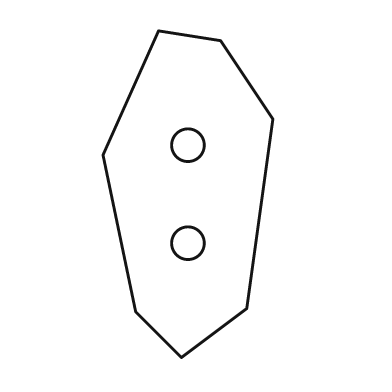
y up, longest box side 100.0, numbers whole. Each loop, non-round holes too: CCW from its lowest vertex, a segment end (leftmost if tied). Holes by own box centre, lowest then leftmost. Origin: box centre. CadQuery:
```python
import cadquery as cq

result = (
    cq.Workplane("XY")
    .moveTo(-2.0, -50.0)
    .lineTo(18.0, -35.0)
    .lineTo(26.0, 23.0)
    .lineTo(10.0, 47.0)
    .lineTo(-9.0, 50.0)
    .lineTo(-26.0, 12.0)
    .lineTo(-16.0, -36.0)
    .close()
    .moveTo(0.0, -15.0)
    .circle(5.0)
    .moveTo(0.0, 15.0)
    .circle(5.0)
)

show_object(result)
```